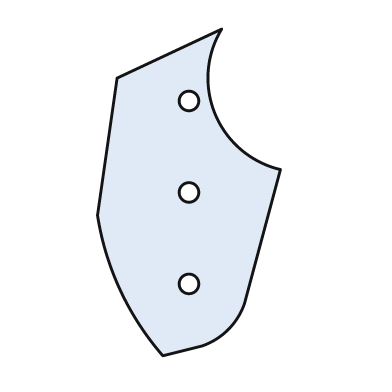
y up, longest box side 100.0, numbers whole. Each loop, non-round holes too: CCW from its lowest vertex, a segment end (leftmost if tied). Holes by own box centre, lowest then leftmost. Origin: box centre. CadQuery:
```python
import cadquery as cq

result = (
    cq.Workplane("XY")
    .moveTo(-8.0, -50.0)
    .lineTo(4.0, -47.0)
    .threePointArc((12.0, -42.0), (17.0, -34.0))
    .lineTo(28.0, 7.0)
    .threePointArc((8.0, 24.0), (10.0, 50.0))
    .lineTo(-22.0, 35.0)
    .lineTo(-28.0, -7.0)
    .threePointArc((-21.0, -30.0), (-8.0, -50.0))
    .close()
    .moveTo(0.0, -28.0)
    .circle(3.0)
    .moveTo(0.0, 0.0)
    .circle(3.0)
    .moveTo(0.0, 28.0)
    .circle(3.0)
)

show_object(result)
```